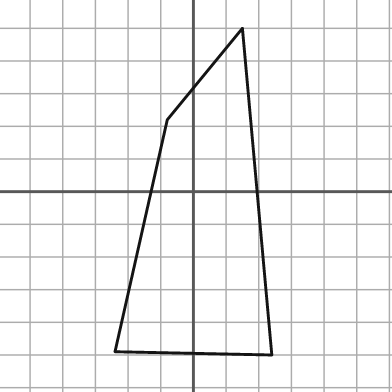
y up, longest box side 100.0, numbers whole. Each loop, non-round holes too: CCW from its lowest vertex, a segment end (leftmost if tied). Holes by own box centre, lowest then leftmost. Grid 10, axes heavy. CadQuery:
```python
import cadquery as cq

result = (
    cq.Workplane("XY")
    .moveTo(24.0, -50.0)
    .lineTo(15.0, 50.0)
    .lineTo(-8.0, 22.0)
    .lineTo(-24.0, -49.0)
    .close()
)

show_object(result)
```